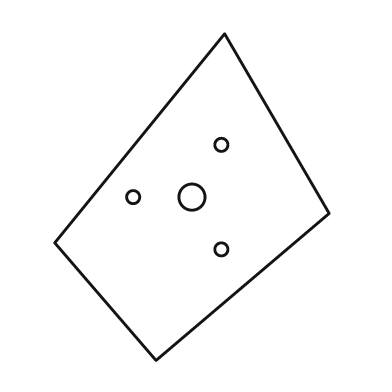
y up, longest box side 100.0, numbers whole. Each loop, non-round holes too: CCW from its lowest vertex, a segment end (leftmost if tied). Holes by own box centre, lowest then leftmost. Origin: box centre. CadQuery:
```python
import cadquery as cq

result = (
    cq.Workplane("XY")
    .moveTo(-11.0, -50.0)
    .lineTo(42.0, -5.0)
    .lineTo(10.0, 50.0)
    .lineTo(-42.0, -14.0)
    .close()
    .moveTo(9.0, -16.0)
    .circle(2.0)
    .moveTo(-18.0, 0.0)
    .circle(2.0)
    .moveTo(0.0, 0.0)
    .circle(4.0)
    .moveTo(9.0, 16.0)
    .circle(2.0)
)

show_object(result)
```